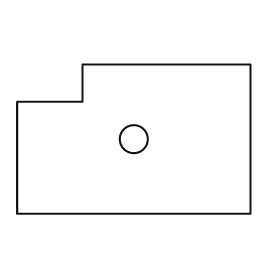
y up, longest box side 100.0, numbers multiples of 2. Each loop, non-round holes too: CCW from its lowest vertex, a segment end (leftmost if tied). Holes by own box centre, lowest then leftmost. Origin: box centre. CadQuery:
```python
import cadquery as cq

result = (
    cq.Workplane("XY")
    .moveTo(-50.0, -32.0)
    .lineTo(50.0, -32.0)
    .lineTo(50.0, 32.0)
    .lineTo(-22.0, 32.0)
    .lineTo(-22.0, 16.0)
    .lineTo(-50.0, 16.0)
    .close()
    .moveTo(0.0, 0.0)
    .circle(6.0)
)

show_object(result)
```